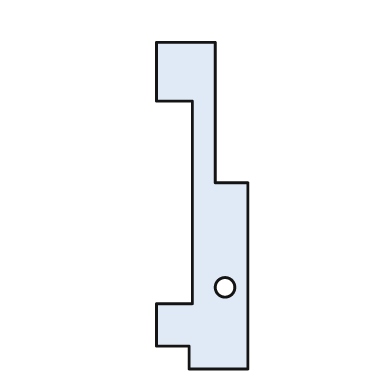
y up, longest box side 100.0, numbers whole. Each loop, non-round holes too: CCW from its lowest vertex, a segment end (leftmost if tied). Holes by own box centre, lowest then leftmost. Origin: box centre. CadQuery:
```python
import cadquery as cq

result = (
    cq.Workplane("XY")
    .moveTo(-4.0, -50.0)
    .lineTo(14.0, -50.0)
    .lineTo(14.0, 7.0)
    .lineTo(4.0, 7.0)
    .lineTo(4.0, 50.0)
    .lineTo(-14.0, 50.0)
    .lineTo(-14.0, 32.0)
    .lineTo(-3.0, 32.0)
    .lineTo(-3.0, -30.0)
    .lineTo(-14.0, -30.0)
    .lineTo(-14.0, -43.0)
    .lineTo(-4.0, -43.0)
    .close()
    .moveTo(7.0, -25.0)
    .circle(3.0)
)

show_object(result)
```